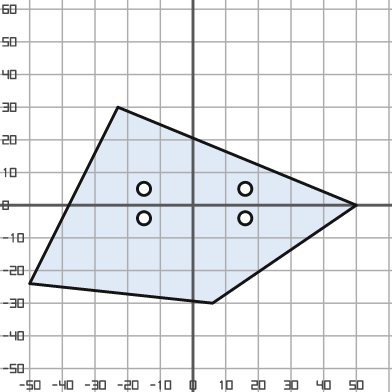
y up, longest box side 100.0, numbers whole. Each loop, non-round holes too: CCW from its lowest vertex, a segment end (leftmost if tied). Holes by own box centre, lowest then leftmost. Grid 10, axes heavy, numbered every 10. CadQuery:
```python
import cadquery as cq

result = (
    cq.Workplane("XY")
    .moveTo(6.0, -30.0)
    .lineTo(50.0, 0.0)
    .lineTo(-23.0, 30.0)
    .lineTo(-50.0, -24.0)
    .close()
    .moveTo(-15.0, -4.0)
    .circle(2.0)
    .moveTo(16.0, -4.0)
    .circle(2.0)
    .moveTo(-15.0, 5.0)
    .circle(2.0)
    .moveTo(16.0, 5.0)
    .circle(2.0)
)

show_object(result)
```